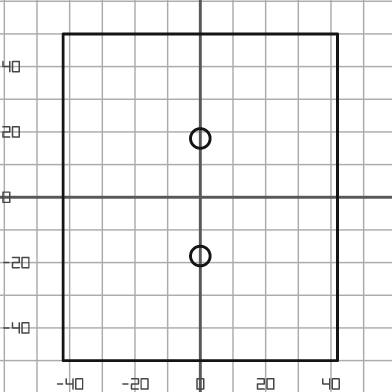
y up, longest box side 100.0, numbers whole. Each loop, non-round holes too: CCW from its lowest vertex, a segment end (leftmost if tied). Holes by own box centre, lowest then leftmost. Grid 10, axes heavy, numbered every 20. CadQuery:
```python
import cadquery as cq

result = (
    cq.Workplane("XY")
    .moveTo(-42.0, -50.0)
    .lineTo(42.0, -50.0)
    .lineTo(42.0, 50.0)
    .lineTo(-42.0, 50.0)
    .close()
    .moveTo(0.0, -18.0)
    .circle(3.0)
    .moveTo(0.0, 18.0)
    .circle(3.0)
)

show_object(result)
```